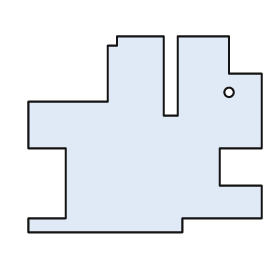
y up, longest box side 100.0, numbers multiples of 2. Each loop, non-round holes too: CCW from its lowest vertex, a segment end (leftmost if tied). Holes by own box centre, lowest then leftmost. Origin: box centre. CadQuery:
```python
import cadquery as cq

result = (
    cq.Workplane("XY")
    .moveTo(-50.0, -42.0)
    .lineTo(16.0, -42.0)
    .lineTo(16.0, -36.0)
    .lineTo(50.0, -36.0)
    .lineTo(50.0, -22.0)
    .lineTo(32.0, -22.0)
    .lineTo(32.0, -6.0)
    .lineTo(50.0, -6.0)
    .lineTo(50.0, 26.0)
    .lineTo(36.0, 26.0)
    .lineTo(36.0, 42.0)
    .lineTo(14.0, 42.0)
    .lineTo(14.0, 8.0)
    .lineTo(8.0, 8.0)
    .lineTo(8.0, 42.0)
    .lineTo(-12.0, 42.0)
    .lineTo(-12.0, 38.0)
    .lineTo(-16.0, 38.0)
    .lineTo(-16.0, 14.0)
    .lineTo(-50.0, 14.0)
    .lineTo(-50.0, -6.0)
    .lineTo(-34.0, -6.0)
    .lineTo(-34.0, -36.0)
    .lineTo(-50.0, -36.0)
    .close()
    .moveTo(36.0, 18.0)
    .circle(2.0)
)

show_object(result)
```